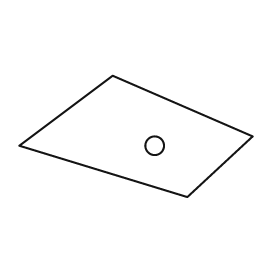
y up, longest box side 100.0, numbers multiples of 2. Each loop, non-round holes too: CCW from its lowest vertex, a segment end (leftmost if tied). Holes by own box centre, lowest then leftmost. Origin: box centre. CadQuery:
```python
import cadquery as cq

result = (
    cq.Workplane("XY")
    .moveTo(22.0, -26.0)
    .lineTo(50.0, 0.0)
    .lineTo(-10.0, 26.0)
    .lineTo(-50.0, -4.0)
    .close()
    .moveTo(8.0, -4.0)
    .circle(4.0)
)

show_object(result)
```